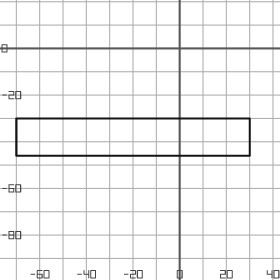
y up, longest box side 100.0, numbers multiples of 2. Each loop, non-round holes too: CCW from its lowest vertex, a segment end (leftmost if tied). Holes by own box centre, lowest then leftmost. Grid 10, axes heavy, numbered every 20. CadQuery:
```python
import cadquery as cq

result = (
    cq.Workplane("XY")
    .moveTo(-70.0, -46.0)
    .lineTo(30.0, -46.0)
    .lineTo(30.0, -30.0)
    .lineTo(-70.0, -30.0)
    .close()
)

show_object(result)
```